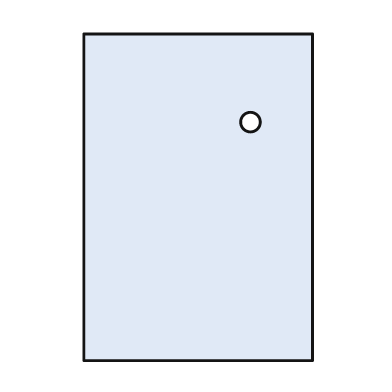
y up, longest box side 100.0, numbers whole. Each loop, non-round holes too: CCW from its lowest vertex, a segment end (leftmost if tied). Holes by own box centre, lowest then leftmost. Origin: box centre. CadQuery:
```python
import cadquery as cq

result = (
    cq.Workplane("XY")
    .moveTo(-35.0, -50.0)
    .lineTo(35.0, -50.0)
    .lineTo(35.0, 50.0)
    .lineTo(-35.0, 50.0)
    .close()
    .moveTo(16.0, 23.0)
    .circle(3.0)
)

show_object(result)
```